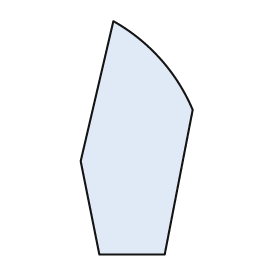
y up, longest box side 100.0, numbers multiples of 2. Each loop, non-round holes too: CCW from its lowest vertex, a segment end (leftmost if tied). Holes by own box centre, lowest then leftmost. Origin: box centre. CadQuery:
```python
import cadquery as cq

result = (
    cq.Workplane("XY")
    .moveTo(-16.0, -50.0)
    .lineTo(12.0, -50.0)
    .lineTo(24.0, 12.0)
    .threePointArc((10.0, 34.0), (-10.0, 50.0))
    .lineTo(-24.0, -10.0)
    .close()
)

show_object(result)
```